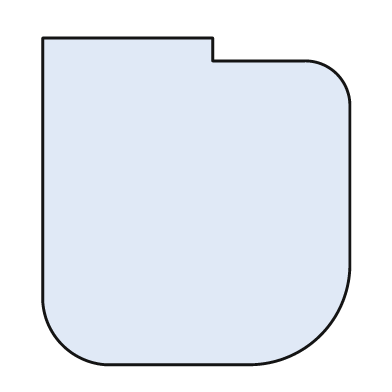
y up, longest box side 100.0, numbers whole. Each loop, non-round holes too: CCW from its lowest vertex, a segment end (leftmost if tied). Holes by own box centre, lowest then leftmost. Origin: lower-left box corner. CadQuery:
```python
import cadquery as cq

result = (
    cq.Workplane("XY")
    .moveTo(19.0, 0.0)
    .lineTo(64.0, 0.0)
    .threePointArc((85.0, 9.0), (94.0, 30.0))
    .lineTo(94.0, 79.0)
    .threePointArc((90.0, 89.0), (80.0, 93.0))
    .lineTo(52.0, 93.0)
    .lineTo(52.0, 100.0)
    .lineTo(0.0, 100.0)
    .lineTo(0.0, 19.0)
    .threePointArc((6.0, 6.0), (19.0, 0.0))
    .close()
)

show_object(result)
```